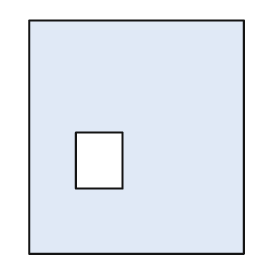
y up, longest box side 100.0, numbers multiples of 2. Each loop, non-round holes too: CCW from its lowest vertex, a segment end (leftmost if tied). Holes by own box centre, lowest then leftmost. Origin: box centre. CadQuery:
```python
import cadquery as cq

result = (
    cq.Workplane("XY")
    .moveTo(-46.0, -50.0)
    .lineTo(46.0, -50.0)
    .lineTo(46.0, 50.0)
    .lineTo(-46.0, 50.0)
    .close()
    .moveTo(-26.0, -22.0)
    .lineTo(-6.0, -22.0)
    .lineTo(-6.0, 2.0)
    .lineTo(-26.0, 2.0)
    .close()
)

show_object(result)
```